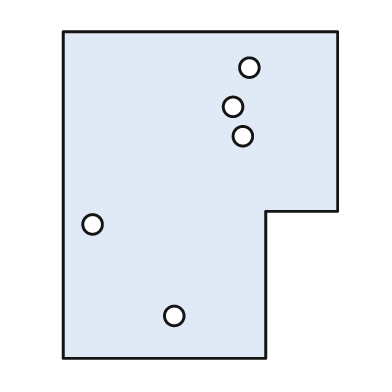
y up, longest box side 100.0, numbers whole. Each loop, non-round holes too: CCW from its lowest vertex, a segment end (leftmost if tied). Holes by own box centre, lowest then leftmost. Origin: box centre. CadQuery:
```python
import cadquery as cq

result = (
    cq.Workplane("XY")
    .moveTo(-42.0, -50.0)
    .lineTo(20.0, -50.0)
    .lineTo(20.0, -5.0)
    .lineTo(42.0, -5.0)
    .lineTo(42.0, 50.0)
    .lineTo(-42.0, 50.0)
    .close()
    .moveTo(-8.0, -37.0)
    .circle(3.0)
    .moveTo(-33.0, -9.0)
    .circle(3.0)
    .moveTo(13.0, 18.0)
    .circle(3.0)
    .moveTo(10.0, 27.0)
    .circle(3.0)
    .moveTo(15.0, 39.0)
    .circle(3.0)
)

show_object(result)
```